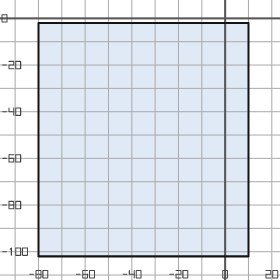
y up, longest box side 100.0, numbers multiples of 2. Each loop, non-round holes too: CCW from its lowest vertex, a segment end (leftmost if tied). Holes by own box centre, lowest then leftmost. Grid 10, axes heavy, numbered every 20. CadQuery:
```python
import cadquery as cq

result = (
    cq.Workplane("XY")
    .moveTo(-80.0, -102.0)
    .lineTo(10.0, -102.0)
    .lineTo(10.0, -2.0)
    .lineTo(-80.0, -2.0)
    .close()
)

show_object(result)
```